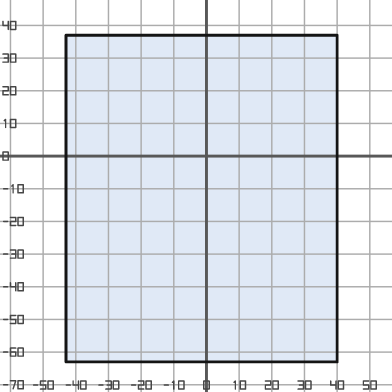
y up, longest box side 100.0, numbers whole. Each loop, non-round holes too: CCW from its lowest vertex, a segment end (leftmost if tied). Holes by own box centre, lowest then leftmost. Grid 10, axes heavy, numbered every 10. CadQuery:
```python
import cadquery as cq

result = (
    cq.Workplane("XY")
    .moveTo(-43.0, -63.0)
    .lineTo(40.0, -63.0)
    .lineTo(40.0, 37.0)
    .lineTo(-43.0, 37.0)
    .close()
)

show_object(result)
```